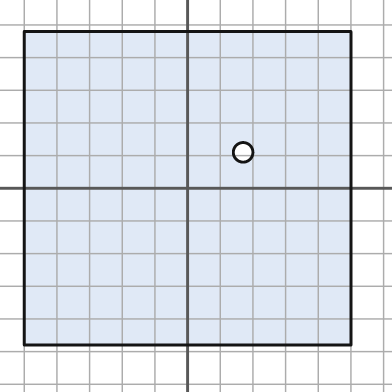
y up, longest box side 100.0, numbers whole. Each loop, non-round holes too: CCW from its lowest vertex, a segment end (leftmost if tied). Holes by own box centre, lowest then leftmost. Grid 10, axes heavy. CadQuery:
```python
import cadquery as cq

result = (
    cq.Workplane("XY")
    .moveTo(-50.0, -48.0)
    .lineTo(50.0, -48.0)
    .lineTo(50.0, 48.0)
    .lineTo(-50.0, 48.0)
    .close()
    .moveTo(17.0, 11.0)
    .circle(3.0)
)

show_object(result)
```